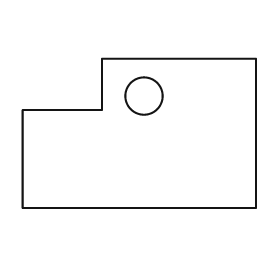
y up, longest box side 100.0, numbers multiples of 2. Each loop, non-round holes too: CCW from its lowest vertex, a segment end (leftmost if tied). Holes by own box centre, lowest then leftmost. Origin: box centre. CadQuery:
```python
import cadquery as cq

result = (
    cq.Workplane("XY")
    .moveTo(-50.0, -32.0)
    .lineTo(50.0, -32.0)
    .lineTo(50.0, 32.0)
    .lineTo(-16.0, 32.0)
    .lineTo(-16.0, 10.0)
    .lineTo(-50.0, 10.0)
    .close()
    .moveTo(2.0, 16.0)
    .circle(8.0)
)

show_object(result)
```